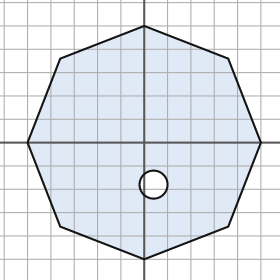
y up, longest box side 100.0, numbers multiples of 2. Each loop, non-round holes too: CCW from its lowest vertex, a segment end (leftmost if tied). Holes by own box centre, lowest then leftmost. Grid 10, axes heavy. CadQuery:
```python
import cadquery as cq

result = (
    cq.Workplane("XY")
    .moveTo(0.0, -50.0)
    .lineTo(36.0, -36.0)
    .lineTo(50.0, 0.0)
    .lineTo(36.0, 36.0)
    .lineTo(0.0, 50.0)
    .lineTo(-36.0, 36.0)
    .lineTo(-50.0, 0.0)
    .lineTo(-36.0, -36.0)
    .close()
    .moveTo(4.0, -18.0)
    .circle(6.0)
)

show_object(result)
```